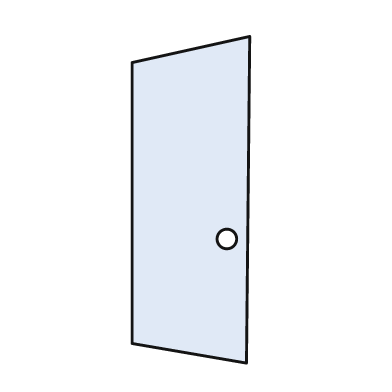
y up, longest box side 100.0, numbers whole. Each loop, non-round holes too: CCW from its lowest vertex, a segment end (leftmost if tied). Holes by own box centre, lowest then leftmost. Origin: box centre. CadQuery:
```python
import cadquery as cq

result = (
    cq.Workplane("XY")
    .moveTo(17.0, -50.0)
    .lineTo(18.0, 50.0)
    .lineTo(-18.0, 42.0)
    .lineTo(-18.0, -44.0)
    .close()
    .moveTo(11.0, -12.0)
    .circle(3.0)
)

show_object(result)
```